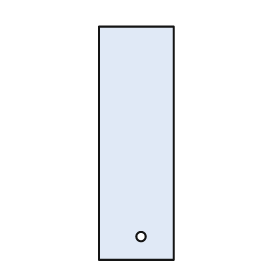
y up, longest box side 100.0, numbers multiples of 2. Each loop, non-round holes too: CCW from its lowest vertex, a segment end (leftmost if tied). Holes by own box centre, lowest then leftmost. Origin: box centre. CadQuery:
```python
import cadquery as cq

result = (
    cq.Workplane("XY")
    .moveTo(-16.0, -50.0)
    .lineTo(16.0, -50.0)
    .lineTo(16.0, 50.0)
    .lineTo(-16.0, 50.0)
    .close()
    .moveTo(2.0, -40.0)
    .circle(2.0)
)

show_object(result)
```